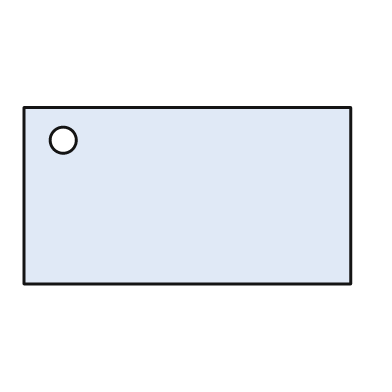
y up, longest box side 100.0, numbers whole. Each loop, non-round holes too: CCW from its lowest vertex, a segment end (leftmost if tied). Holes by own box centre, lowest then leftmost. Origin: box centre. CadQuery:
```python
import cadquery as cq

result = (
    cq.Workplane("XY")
    .moveTo(-50.0, -27.0)
    .lineTo(50.0, -27.0)
    .lineTo(50.0, 27.0)
    .lineTo(-50.0, 27.0)
    .close()
    .moveTo(-38.0, 17.0)
    .circle(4.0)
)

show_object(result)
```